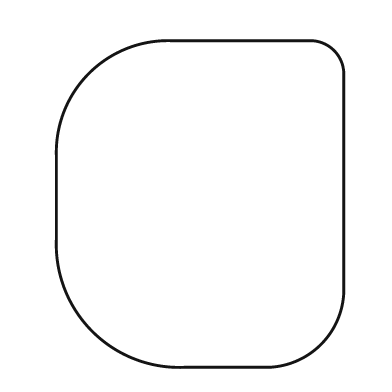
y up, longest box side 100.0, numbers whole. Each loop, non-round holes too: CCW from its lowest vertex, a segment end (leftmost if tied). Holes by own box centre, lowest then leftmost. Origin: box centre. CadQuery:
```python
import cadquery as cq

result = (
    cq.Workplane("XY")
    .moveTo(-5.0, -50.0)
    .lineTo(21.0, -50.0)
    .threePointArc((37.0, -43.0), (44.0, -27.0))
    .lineTo(44.0, 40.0)
    .threePointArc((41.0, 47.0), (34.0, 50.0))
    .lineTo(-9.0, 50.0)
    .threePointArc((-34.0, 40.0), (-44.0, 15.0))
    .lineTo(-44.0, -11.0)
    .threePointArc((-33.0, -39.0), (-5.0, -50.0))
    .close()
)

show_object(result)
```